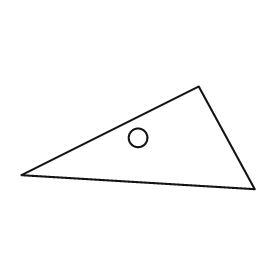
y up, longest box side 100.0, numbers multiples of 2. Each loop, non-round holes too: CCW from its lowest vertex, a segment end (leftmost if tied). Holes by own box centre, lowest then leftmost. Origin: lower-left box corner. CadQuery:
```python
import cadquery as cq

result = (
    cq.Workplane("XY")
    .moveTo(100.0, 0.0)
    .lineTo(76.0, 44.0)
    .lineTo(0.0, 6.0)
    .close()
    .moveTo(50.0, 22.0)
    .circle(4.0)
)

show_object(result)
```